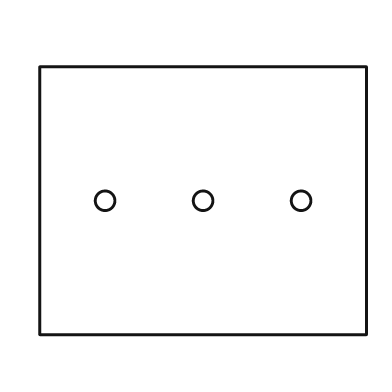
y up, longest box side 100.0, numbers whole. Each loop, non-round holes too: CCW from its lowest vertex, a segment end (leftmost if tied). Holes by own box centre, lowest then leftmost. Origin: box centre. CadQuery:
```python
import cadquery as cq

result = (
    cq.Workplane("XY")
    .moveTo(-50.0, -41.0)
    .lineTo(50.0, -41.0)
    .lineTo(50.0, 41.0)
    .lineTo(-50.0, 41.0)
    .close()
    .moveTo(-30.0, 0.0)
    .circle(3.0)
    .moveTo(0.0, 0.0)
    .circle(3.0)
    .moveTo(30.0, 0.0)
    .circle(3.0)
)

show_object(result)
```